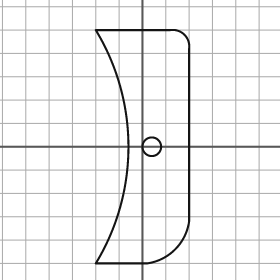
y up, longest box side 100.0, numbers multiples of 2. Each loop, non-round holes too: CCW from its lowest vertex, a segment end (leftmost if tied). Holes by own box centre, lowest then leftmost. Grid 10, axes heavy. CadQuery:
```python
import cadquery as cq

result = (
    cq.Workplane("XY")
    .moveTo(-20.0, -50.0)
    .lineTo(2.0, -50.0)
    .threePointArc((14.0, -44.0), (20.0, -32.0))
    .lineTo(20.0, 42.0)
    .threePointArc((18.0, 48.0), (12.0, 50.0))
    .lineTo(-20.0, 50.0)
    .threePointArc((-6.0, 0.0), (-20.0, -50.0))
    .close()
    .moveTo(4.0, 0.0)
    .circle(4.0)
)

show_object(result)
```